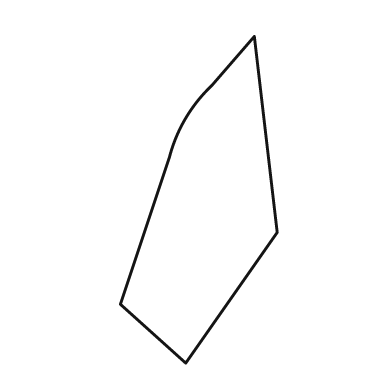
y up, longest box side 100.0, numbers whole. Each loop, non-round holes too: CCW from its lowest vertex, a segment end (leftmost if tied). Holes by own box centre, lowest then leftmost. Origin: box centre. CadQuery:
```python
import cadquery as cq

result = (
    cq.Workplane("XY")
    .moveTo(-4.0, -50.0)
    .lineTo(24.0, -10.0)
    .lineTo(17.0, 50.0)
    .lineTo(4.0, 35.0)
    .threePointArc((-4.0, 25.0), (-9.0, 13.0))
    .lineTo(-24.0, -32.0)
    .close()
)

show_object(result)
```